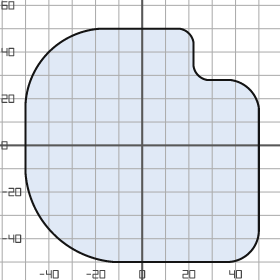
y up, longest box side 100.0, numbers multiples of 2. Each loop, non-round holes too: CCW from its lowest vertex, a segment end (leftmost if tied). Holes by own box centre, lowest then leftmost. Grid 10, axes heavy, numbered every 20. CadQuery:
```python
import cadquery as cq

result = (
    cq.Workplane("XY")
    .moveTo(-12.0, -50.0)
    .lineTo(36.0, -50.0)
    .threePointArc((46.0, -46.0), (50.0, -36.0))
    .lineTo(50.0, 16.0)
    .threePointArc((46.0, 24.0), (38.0, 28.0))
    .lineTo(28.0, 28.0)
    .threePointArc((24.0, 30.0), (22.0, 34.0))
    .lineTo(22.0, 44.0)
    .threePointArc((20.0, 48.0), (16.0, 50.0))
    .lineTo(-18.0, 50.0)
    .threePointArc((-40.0, 40.0), (-50.0, 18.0))
    .lineTo(-50.0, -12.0)
    .threePointArc((-38.0, -38.0), (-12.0, -50.0))
    .close()
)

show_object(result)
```